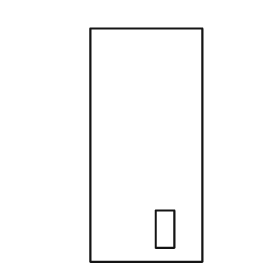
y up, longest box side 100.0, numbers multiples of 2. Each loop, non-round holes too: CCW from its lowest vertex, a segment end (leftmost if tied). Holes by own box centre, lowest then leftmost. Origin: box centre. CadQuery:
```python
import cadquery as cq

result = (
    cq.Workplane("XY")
    .moveTo(-24.0, -50.0)
    .lineTo(24.0, -50.0)
    .lineTo(24.0, 50.0)
    .lineTo(-24.0, 50.0)
    .close()
    .moveTo(4.0, -44.0)
    .lineTo(12.0, -44.0)
    .lineTo(12.0, -28.0)
    .lineTo(4.0, -28.0)
    .close()
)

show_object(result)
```